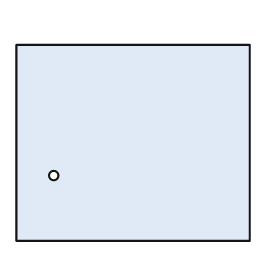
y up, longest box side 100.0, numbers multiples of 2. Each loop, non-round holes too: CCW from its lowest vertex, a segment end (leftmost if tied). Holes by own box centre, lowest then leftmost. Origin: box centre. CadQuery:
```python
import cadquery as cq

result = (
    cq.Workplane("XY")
    .moveTo(-50.0, -42.0)
    .lineTo(50.0, -42.0)
    .lineTo(50.0, 42.0)
    .lineTo(-50.0, 42.0)
    .close()
    .moveTo(-34.0, -14.0)
    .circle(2.0)
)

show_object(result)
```